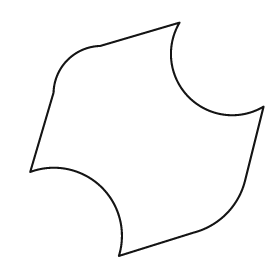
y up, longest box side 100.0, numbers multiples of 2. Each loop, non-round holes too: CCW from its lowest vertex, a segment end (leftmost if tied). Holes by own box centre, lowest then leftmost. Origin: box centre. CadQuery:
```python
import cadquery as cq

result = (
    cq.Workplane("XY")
    .moveTo(-12.0, -50.0)
    .lineTo(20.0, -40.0)
    .threePointArc((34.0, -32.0), (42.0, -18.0))
    .lineTo(50.0, 14.0)
    .threePointArc((18.0, 18.0), (14.0, 50.0))
    .lineTo(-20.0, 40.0)
    .threePointArc((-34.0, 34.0), (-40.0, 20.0))
    .lineTo(-50.0, -14.0)
    .threePointArc((-20.0, -20.0), (-12.0, -50.0))
    .close()
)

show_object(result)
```